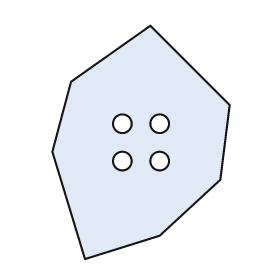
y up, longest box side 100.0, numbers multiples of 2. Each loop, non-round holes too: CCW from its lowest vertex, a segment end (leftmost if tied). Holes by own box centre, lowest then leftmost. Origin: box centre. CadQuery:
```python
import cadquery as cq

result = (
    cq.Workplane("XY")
    .moveTo(-24.0, -50.0)
    .lineTo(8.0, -40.0)
    .lineTo(34.0, -16.0)
    .lineTo(38.0, 16.0)
    .lineTo(4.0, 50.0)
    .lineTo(-30.0, 26.0)
    .lineTo(-38.0, -4.0)
    .close()
    .moveTo(-8.0, -8.0)
    .circle(4.0)
    .moveTo(8.0, -8.0)
    .circle(4.0)
    .moveTo(-8.0, 8.0)
    .circle(4.0)
    .moveTo(8.0, 8.0)
    .circle(4.0)
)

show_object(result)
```